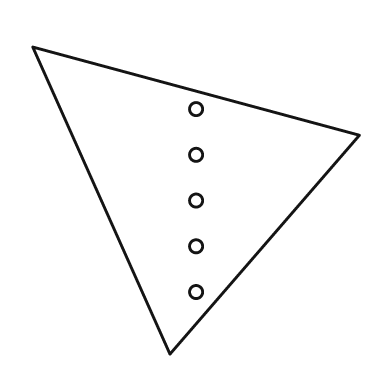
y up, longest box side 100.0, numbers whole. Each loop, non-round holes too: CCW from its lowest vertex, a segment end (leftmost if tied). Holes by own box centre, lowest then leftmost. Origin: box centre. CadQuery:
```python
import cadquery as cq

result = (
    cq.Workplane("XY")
    .moveTo(-8.0, -47.0)
    .lineTo(50.0, 20.0)
    .lineTo(-50.0, 47.0)
    .close()
    .moveTo(0.0, -28.0)
    .circle(2.0)
    .moveTo(0.0, -14.0)
    .circle(2.0)
    .moveTo(0.0, 0.0)
    .circle(2.0)
    .moveTo(0.0, 14.0)
    .circle(2.0)
    .moveTo(0.0, 28.0)
    .circle(2.0)
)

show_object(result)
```